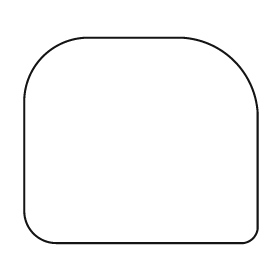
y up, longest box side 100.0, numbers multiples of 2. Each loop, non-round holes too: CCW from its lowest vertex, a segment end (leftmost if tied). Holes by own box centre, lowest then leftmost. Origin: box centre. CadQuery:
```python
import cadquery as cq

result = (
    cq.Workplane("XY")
    .moveTo(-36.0, -44.0)
    .lineTo(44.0, -44.0)
    .threePointArc((48.0, -42.0), (50.0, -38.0))
    .lineTo(50.0, 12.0)
    .threePointArc((40.0, 34.0), (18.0, 44.0))
    .lineTo(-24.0, 44.0)
    .threePointArc((-42.0, 36.0), (-50.0, 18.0))
    .lineTo(-50.0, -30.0)
    .threePointArc((-46.0, -40.0), (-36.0, -44.0))
    .close()
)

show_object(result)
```